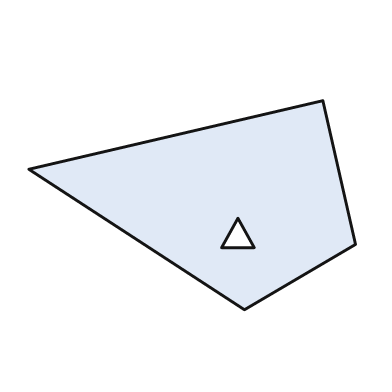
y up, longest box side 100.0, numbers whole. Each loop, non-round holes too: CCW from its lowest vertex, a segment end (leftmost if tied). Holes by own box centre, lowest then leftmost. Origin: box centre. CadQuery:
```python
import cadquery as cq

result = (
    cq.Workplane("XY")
    .moveTo(16.0, -32.0)
    .lineTo(50.0, -12.0)
    .lineTo(40.0, 32.0)
    .lineTo(-50.0, 11.0)
    .close()
    .moveTo(9.0, -13.0)
    .lineTo(19.0, -13.0)
    .lineTo(14.0, -4.0)
    .close()
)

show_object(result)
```